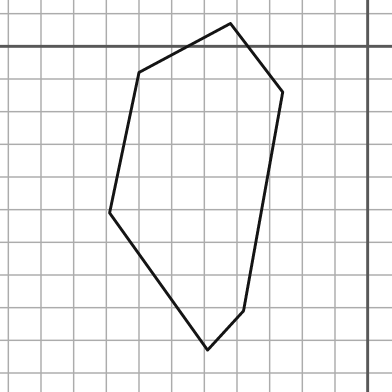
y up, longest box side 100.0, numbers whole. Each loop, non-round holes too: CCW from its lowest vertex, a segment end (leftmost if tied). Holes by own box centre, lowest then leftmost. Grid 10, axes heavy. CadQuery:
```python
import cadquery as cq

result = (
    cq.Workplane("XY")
    .moveTo(-49.0, -93.0)
    .lineTo(-38.0, -81.0)
    .lineTo(-26.0, -14.0)
    .lineTo(-42.0, 7.0)
    .lineTo(-70.0, -8.0)
    .lineTo(-79.0, -51.0)
    .close()
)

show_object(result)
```